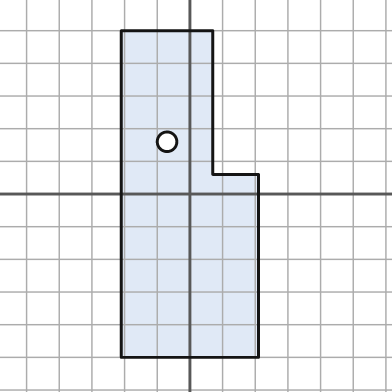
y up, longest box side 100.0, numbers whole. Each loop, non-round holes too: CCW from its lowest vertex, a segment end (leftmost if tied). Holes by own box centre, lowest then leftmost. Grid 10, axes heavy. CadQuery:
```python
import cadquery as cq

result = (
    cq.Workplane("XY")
    .moveTo(-21.0, -50.0)
    .lineTo(21.0, -50.0)
    .lineTo(21.0, 6.0)
    .lineTo(7.0, 6.0)
    .lineTo(7.0, 50.0)
    .lineTo(-21.0, 50.0)
    .close()
    .moveTo(-7.0, 16.0)
    .circle(3.0)
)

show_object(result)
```